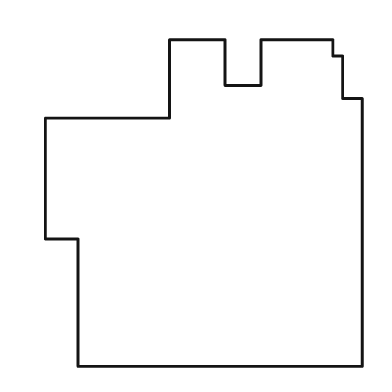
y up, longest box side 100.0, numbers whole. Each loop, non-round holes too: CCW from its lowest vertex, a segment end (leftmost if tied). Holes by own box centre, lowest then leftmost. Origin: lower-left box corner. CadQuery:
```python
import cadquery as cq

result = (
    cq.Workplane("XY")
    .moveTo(10.0, 0.0)
    .lineTo(97.0, 0.0)
    .lineTo(97.0, 82.0)
    .lineTo(91.0, 82.0)
    .lineTo(91.0, 95.0)
    .lineTo(88.0, 95.0)
    .lineTo(88.0, 100.0)
    .lineTo(66.0, 100.0)
    .lineTo(66.0, 86.0)
    .lineTo(55.0, 86.0)
    .lineTo(55.0, 100.0)
    .lineTo(38.0, 100.0)
    .lineTo(38.0, 76.0)
    .lineTo(0.0, 76.0)
    .lineTo(0.0, 39.0)
    .lineTo(10.0, 39.0)
    .close()
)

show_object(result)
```